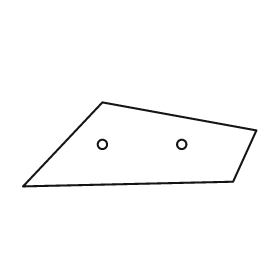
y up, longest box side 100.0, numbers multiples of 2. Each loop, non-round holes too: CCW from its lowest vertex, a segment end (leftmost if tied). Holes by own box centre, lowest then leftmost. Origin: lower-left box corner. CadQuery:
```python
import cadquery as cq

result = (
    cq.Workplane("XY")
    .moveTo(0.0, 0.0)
    .lineTo(90.0, 2.0)
    .lineTo(100.0, 24.0)
    .lineTo(34.0, 36.0)
    .close()
    .moveTo(34.0, 18.0)
    .circle(2.0)
    .moveTo(68.0, 18.0)
    .circle(2.0)
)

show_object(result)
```